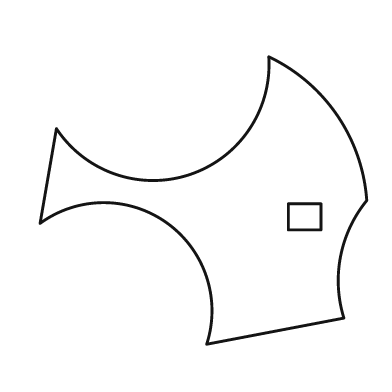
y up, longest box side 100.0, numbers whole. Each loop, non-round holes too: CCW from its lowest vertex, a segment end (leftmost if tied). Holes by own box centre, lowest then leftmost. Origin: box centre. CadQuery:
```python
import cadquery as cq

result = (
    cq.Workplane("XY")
    .moveTo(1.0, -44.0)
    .lineTo(43.0, -36.0)
    .threePointArc((42.0, -17.0), (50.0, 0.0))
    .threePointArc((41.0, 26.0), (20.0, 44.0))
    .threePointArc((-4.0, 8.0), (-45.0, 22.0))
    .lineTo(-50.0, -7.0)
    .threePointArc((-11.0, -7.0), (1.0, -44.0))
    .close()
    .moveTo(26.0, -9.0)
    .lineTo(36.0, -9.0)
    .lineTo(36.0, -1.0)
    .lineTo(26.0, -1.0)
    .close()
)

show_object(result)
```